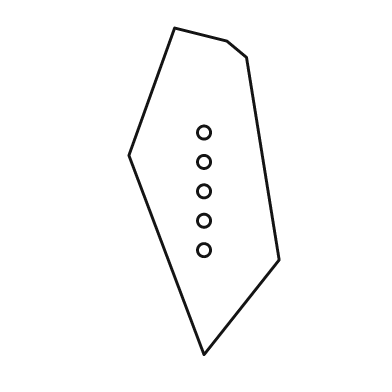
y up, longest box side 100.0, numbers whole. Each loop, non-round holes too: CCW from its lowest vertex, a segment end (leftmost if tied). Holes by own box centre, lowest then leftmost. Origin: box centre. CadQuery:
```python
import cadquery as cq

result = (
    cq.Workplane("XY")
    .moveTo(0.0, -50.0)
    .lineTo(23.0, -21.0)
    .lineTo(13.0, 41.0)
    .lineTo(7.0, 46.0)
    .lineTo(-9.0, 50.0)
    .lineTo(-23.0, 11.0)
    .close()
    .moveTo(0.0, -18.0)
    .circle(2.0)
    .moveTo(0.0, -9.0)
    .circle(2.0)
    .moveTo(0.0, 0.0)
    .circle(2.0)
    .moveTo(0.0, 9.0)
    .circle(2.0)
    .moveTo(0.0, 18.0)
    .circle(2.0)
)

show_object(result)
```